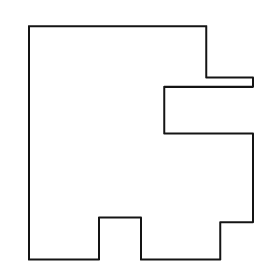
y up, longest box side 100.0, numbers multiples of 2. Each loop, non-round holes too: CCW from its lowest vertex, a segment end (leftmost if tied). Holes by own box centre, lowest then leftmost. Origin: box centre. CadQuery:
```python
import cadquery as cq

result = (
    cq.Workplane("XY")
    .moveTo(-48.0, -50.0)
    .lineTo(-18.0, -50.0)
    .lineTo(-18.0, -32.0)
    .lineTo(0.0, -32.0)
    .lineTo(0.0, -50.0)
    .lineTo(34.0, -50.0)
    .lineTo(34.0, -34.0)
    .lineTo(48.0, -34.0)
    .lineTo(48.0, 4.0)
    .lineTo(10.0, 4.0)
    .lineTo(10.0, 24.0)
    .lineTo(48.0, 24.0)
    .lineTo(48.0, 28.0)
    .lineTo(28.0, 28.0)
    .lineTo(28.0, 50.0)
    .lineTo(-48.0, 50.0)
    .close()
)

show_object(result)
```